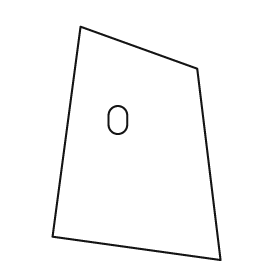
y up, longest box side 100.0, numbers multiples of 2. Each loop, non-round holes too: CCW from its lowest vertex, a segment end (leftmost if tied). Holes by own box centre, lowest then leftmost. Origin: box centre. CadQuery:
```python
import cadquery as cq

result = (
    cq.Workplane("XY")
    .moveTo(36.0, -50.0)
    .lineTo(26.0, 32.0)
    .lineTo(-24.0, 50.0)
    .lineTo(-36.0, -40.0)
    .close()
    .moveTo(-12.0, 8.0)
    .threePointArc((-8.0, 4.0), (-4.0, 8.0))
    .lineTo(-4.0, 12.0)
    .threePointArc((-8.0, 16.0), (-12.0, 12.0))
    .close()
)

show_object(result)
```